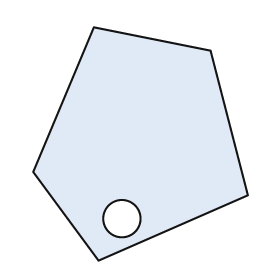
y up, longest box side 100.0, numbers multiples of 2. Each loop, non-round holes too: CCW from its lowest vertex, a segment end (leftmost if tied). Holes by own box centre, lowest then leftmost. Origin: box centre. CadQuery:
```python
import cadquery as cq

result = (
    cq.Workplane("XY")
    .moveTo(-18.0, -50.0)
    .lineTo(46.0, -22.0)
    .lineTo(30.0, 40.0)
    .lineTo(-20.0, 50.0)
    .lineTo(-46.0, -12.0)
    .close()
    .moveTo(-8.0, -32.0)
    .circle(8.0)
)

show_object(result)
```